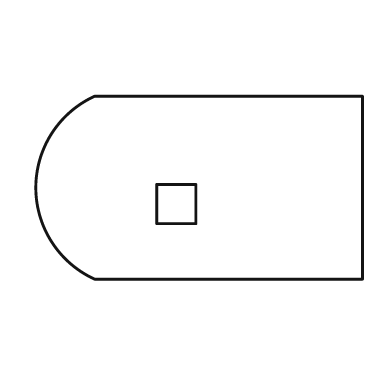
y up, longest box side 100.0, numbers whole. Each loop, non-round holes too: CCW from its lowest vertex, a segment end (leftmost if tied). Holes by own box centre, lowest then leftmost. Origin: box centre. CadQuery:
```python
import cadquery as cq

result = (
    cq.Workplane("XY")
    .moveTo(-32.0, -28.0)
    .lineTo(50.0, -28.0)
    .lineTo(50.0, 28.0)
    .lineTo(-32.0, 28.0)
    .threePointArc((-50.0, 0.0), (-32.0, -28.0))
    .close()
    .moveTo(-13.0, -11.0)
    .lineTo(-1.0, -11.0)
    .lineTo(-1.0, 1.0)
    .lineTo(-13.0, 1.0)
    .close()
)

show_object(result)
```